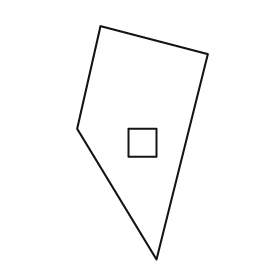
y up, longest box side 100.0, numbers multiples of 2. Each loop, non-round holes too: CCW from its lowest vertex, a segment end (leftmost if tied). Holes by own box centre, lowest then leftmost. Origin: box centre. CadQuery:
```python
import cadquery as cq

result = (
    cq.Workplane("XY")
    .moveTo(6.0, -50.0)
    .lineTo(28.0, 38.0)
    .lineTo(-18.0, 50.0)
    .lineTo(-28.0, 6.0)
    .close()
    .moveTo(-6.0, -6.0)
    .lineTo(6.0, -6.0)
    .lineTo(6.0, 6.0)
    .lineTo(-6.0, 6.0)
    .close()
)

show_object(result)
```